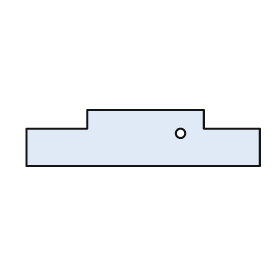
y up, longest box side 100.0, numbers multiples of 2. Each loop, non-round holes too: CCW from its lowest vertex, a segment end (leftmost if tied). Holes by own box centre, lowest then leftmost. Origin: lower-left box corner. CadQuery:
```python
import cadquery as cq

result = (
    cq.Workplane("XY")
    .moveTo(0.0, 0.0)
    .lineTo(100.0, 0.0)
    .lineTo(100.0, 16.0)
    .lineTo(76.0, 16.0)
    .lineTo(76.0, 24.0)
    .lineTo(26.0, 24.0)
    .lineTo(26.0, 16.0)
    .lineTo(0.0, 16.0)
    .close()
    .moveTo(66.0, 14.0)
    .circle(2.0)
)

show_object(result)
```